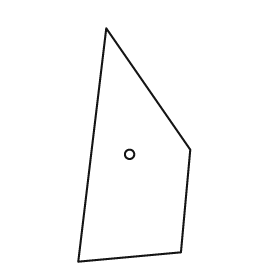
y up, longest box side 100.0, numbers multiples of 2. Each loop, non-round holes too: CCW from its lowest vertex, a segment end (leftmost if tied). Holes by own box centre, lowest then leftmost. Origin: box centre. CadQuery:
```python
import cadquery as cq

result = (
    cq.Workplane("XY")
    .moveTo(-24.0, -50.0)
    .lineTo(20.0, -46.0)
    .lineTo(24.0, -2.0)
    .lineTo(-12.0, 50.0)
    .close()
    .moveTo(-2.0, -4.0)
    .circle(2.0)
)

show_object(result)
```